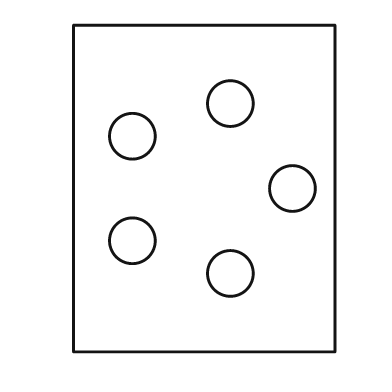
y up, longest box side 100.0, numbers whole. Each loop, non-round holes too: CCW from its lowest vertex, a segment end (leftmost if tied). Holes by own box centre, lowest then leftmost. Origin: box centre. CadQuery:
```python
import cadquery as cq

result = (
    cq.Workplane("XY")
    .moveTo(-40.0, -50.0)
    .lineTo(40.0, -50.0)
    .lineTo(40.0, 50.0)
    .lineTo(-40.0, 50.0)
    .close()
    .moveTo(8.0, -26.0)
    .circle(7.0)
    .moveTo(-22.0, -16.0)
    .circle(7.0)
    .moveTo(27.0, 0.0)
    .circle(7.0)
    .moveTo(-22.0, 16.0)
    .circle(7.0)
    .moveTo(8.0, 26.0)
    .circle(7.0)
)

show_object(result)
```